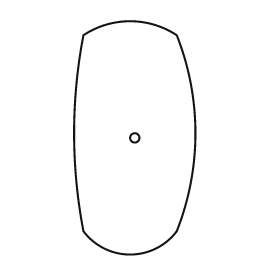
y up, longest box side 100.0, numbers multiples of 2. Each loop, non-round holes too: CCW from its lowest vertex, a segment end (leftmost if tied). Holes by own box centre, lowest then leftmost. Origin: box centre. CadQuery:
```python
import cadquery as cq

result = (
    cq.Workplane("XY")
    .moveTo(-22.0, -40.0)
    .threePointArc((-2.0, -50.0), (18.0, -40.0))
    .threePointArc((26.0, 2.0), (18.0, 44.0))
    .threePointArc((-2.0, 50.0), (-22.0, 44.0))
    .threePointArc((-26.0, 2.0), (-22.0, -40.0))
    .close()
    .moveTo(0.0, 0.0)
    .circle(2.0)
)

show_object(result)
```